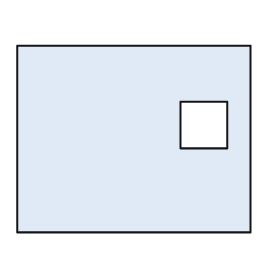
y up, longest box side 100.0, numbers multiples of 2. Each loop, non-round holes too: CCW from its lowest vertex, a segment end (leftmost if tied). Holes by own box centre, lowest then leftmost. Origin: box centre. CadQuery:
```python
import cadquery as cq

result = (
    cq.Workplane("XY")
    .moveTo(-50.0, -40.0)
    .lineTo(50.0, -40.0)
    .lineTo(50.0, 40.0)
    .lineTo(-50.0, 40.0)
    .close()
    .moveTo(20.0, -4.0)
    .lineTo(40.0, -4.0)
    .lineTo(40.0, 16.0)
    .lineTo(20.0, 16.0)
    .close()
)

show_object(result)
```